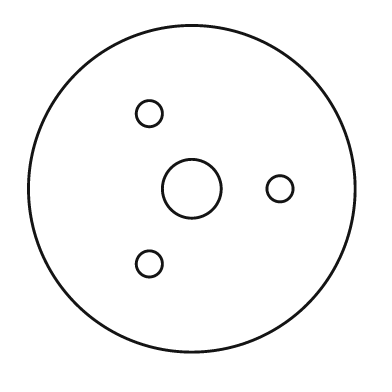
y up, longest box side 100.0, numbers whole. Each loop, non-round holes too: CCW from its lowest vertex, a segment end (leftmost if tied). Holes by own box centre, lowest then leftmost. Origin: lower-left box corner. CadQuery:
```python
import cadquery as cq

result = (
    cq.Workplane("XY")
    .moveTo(50.0, 50.0)
    .circle(50.0)
    .moveTo(37.0, 27.0)
    .circle(4.0)
    .moveTo(50.0, 50.0)
    .circle(9.0)
    .moveTo(77.0, 50.0)
    .circle(4.0)
    .moveTo(37.0, 73.0)
    .circle(4.0)
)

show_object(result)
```